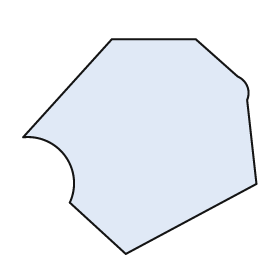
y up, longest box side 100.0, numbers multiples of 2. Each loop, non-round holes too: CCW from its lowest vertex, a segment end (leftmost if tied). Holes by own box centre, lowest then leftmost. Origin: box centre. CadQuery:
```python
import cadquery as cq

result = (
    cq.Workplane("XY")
    .moveTo(-6.0, -46.0)
    .lineTo(50.0, -16.0)
    .lineTo(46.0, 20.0)
    .threePointArc((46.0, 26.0), (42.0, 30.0))
    .lineTo(24.0, 46.0)
    .lineTo(-12.0, 46.0)
    .lineTo(-50.0, 4.0)
    .threePointArc((-32.0, -4.0), (-30.0, -24.0))
    .close()
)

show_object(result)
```